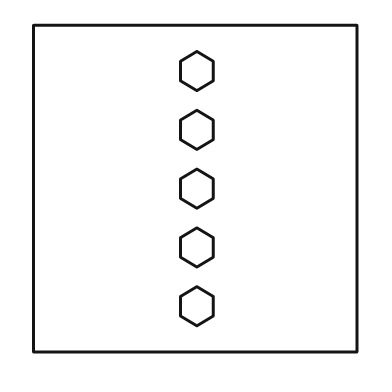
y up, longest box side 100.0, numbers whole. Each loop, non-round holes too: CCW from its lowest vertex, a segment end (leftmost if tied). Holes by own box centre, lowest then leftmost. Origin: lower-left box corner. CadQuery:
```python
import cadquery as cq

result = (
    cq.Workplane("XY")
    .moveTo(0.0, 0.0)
    .lineTo(99.0, 0.0)
    .lineTo(99.0, 100.0)
    .lineTo(0.0, 100.0)
    .close()
    .moveTo(50.0, 8.0)
    .lineTo(55.0, 11.0)
    .lineTo(55.0, 17.0)
    .lineTo(50.0, 20.0)
    .lineTo(45.0, 17.0)
    .lineTo(45.0, 11.0)
    .close()
    .moveTo(50.0, 26.0)
    .lineTo(55.0, 29.0)
    .lineTo(55.0, 35.0)
    .lineTo(50.0, 38.0)
    .lineTo(45.0, 35.0)
    .lineTo(45.0, 29.0)
    .close()
    .moveTo(50.0, 44.0)
    .lineTo(55.0, 47.0)
    .lineTo(55.0, 53.0)
    .lineTo(50.0, 56.0)
    .lineTo(45.0, 53.0)
    .lineTo(45.0, 47.0)
    .close()
    .moveTo(50.0, 62.0)
    .lineTo(55.0, 65.0)
    .lineTo(55.0, 71.0)
    .lineTo(50.0, 74.0)
    .lineTo(45.0, 71.0)
    .lineTo(45.0, 65.0)
    .close()
    .moveTo(50.0, 80.0)
    .lineTo(55.0, 83.0)
    .lineTo(55.0, 89.0)
    .lineTo(50.0, 92.0)
    .lineTo(45.0, 89.0)
    .lineTo(45.0, 83.0)
    .close()
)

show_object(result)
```